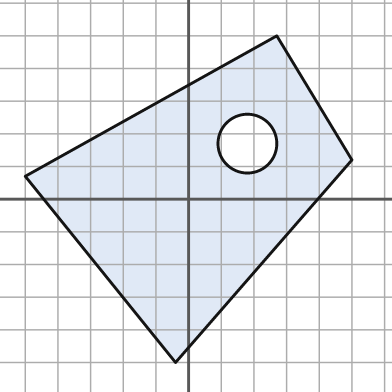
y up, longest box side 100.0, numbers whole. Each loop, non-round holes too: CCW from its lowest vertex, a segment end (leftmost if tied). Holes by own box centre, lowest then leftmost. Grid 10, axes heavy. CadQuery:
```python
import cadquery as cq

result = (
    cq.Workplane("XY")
    .moveTo(-4.0, -50.0)
    .lineTo(50.0, 12.0)
    .lineTo(27.0, 50.0)
    .lineTo(-50.0, 7.0)
    .close()
    .moveTo(18.0, 17.0)
    .circle(9.0)
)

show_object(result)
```